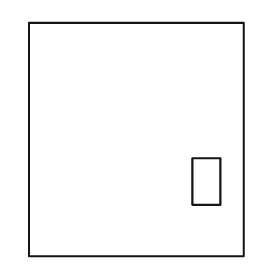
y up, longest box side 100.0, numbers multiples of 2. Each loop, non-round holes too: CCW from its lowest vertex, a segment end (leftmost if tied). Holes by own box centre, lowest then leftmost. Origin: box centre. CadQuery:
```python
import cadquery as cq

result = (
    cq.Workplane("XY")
    .moveTo(-46.0, -50.0)
    .lineTo(46.0, -50.0)
    .lineTo(46.0, 50.0)
    .lineTo(-46.0, 50.0)
    .close()
    .moveTo(24.0, -28.0)
    .lineTo(36.0, -28.0)
    .lineTo(36.0, -8.0)
    .lineTo(24.0, -8.0)
    .close()
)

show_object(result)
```